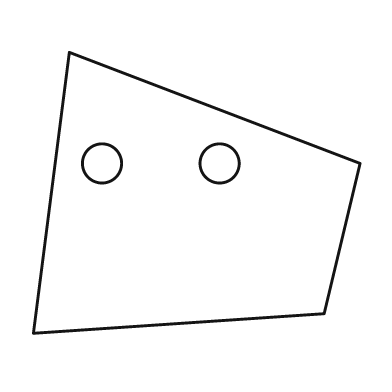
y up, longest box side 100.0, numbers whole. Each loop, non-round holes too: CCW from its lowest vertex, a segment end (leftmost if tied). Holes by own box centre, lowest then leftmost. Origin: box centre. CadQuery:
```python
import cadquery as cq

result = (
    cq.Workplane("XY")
    .moveTo(-50.0, -43.0)
    .lineTo(39.0, -37.0)
    .lineTo(50.0, 9.0)
    .lineTo(-39.0, 43.0)
    .close()
    .moveTo(-29.0, 9.0)
    .circle(6.0)
    .moveTo(7.0, 9.0)
    .circle(6.0)
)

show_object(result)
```